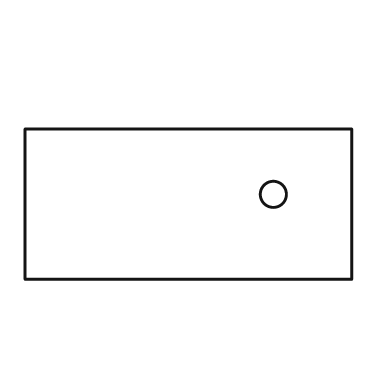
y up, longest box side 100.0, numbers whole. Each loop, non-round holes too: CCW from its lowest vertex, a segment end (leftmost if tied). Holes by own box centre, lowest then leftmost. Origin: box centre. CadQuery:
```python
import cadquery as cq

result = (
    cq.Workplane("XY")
    .moveTo(-50.0, -23.0)
    .lineTo(50.0, -23.0)
    .lineTo(50.0, 23.0)
    .lineTo(-50.0, 23.0)
    .close()
    .moveTo(26.0, 3.0)
    .circle(4.0)
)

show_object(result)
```